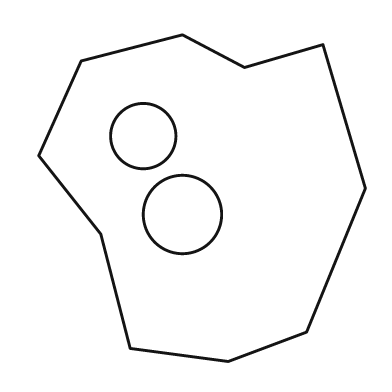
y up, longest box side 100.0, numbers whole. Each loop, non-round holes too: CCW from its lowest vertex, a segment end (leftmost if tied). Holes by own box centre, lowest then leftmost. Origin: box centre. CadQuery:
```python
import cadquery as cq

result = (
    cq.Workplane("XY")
    .moveTo(8.0, -50.0)
    .lineTo(32.0, -41.0)
    .lineTo(50.0, 3.0)
    .lineTo(37.0, 47.0)
    .lineTo(13.0, 40.0)
    .lineTo(-6.0, 50.0)
    .lineTo(-37.0, 42.0)
    .lineTo(-50.0, 13.0)
    .lineTo(-31.0, -11.0)
    .lineTo(-22.0, -46.0)
    .close()
    .moveTo(-6.0, -5.0)
    .circle(12.0)
    .moveTo(-18.0, 19.0)
    .circle(10.0)
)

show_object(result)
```